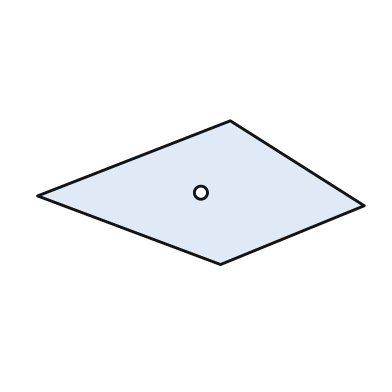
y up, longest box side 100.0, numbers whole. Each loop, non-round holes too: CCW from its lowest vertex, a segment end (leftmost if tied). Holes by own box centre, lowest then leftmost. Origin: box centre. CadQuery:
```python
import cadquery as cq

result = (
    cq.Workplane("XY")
    .moveTo(6.0, -22.0)
    .lineTo(50.0, -4.0)
    .lineTo(9.0, 22.0)
    .lineTo(-50.0, -1.0)
    .close()
    .moveTo(0.0, 0.0)
    .circle(2.0)
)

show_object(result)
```